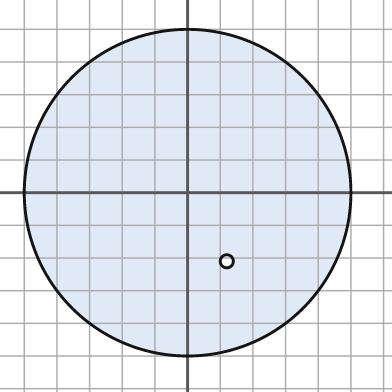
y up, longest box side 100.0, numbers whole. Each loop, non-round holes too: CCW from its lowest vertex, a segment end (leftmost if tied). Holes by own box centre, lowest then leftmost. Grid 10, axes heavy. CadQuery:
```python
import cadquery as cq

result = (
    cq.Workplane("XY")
    .moveTo(0.0, 0.0)
    .circle(50.0)
    .moveTo(12.0, -21.0)
    .circle(2.0)
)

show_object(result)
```